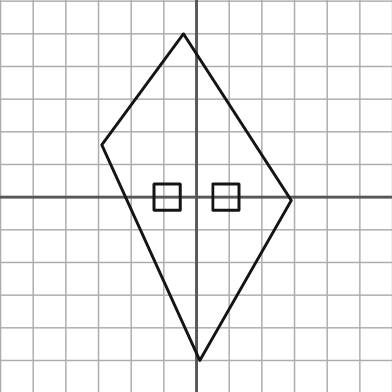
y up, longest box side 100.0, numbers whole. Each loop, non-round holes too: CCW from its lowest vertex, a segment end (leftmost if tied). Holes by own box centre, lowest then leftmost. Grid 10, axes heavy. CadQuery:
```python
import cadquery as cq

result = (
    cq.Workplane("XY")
    .moveTo(1.0, -50.0)
    .lineTo(29.0, -1.0)
    .lineTo(-4.0, 50.0)
    .lineTo(-29.0, 16.0)
    .close()
    .moveTo(-13.0, -4.0)
    .lineTo(-5.0, -4.0)
    .lineTo(-5.0, 4.0)
    .lineTo(-13.0, 4.0)
    .close()
    .moveTo(5.0, -4.0)
    .lineTo(13.0, -4.0)
    .lineTo(13.0, 4.0)
    .lineTo(5.0, 4.0)
    .close()
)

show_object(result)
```